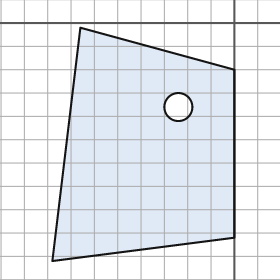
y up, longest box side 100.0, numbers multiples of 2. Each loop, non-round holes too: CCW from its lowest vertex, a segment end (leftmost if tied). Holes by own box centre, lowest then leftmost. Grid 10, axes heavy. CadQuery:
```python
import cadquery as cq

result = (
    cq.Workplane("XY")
    .moveTo(-78.0, -102.0)
    .lineTo(0.0, -92.0)
    .lineTo(0.0, -20.0)
    .lineTo(-66.0, -2.0)
    .close()
    .moveTo(-24.0, -36.0)
    .circle(6.0)
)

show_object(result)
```